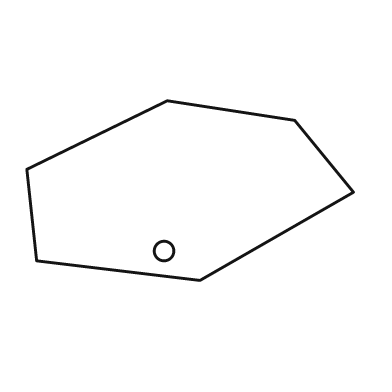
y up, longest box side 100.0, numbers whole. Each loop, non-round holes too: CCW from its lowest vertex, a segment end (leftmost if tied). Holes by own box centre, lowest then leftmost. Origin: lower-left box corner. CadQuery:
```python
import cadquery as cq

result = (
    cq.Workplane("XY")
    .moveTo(53.0, 0.0)
    .lineTo(100.0, 27.0)
    .lineTo(82.0, 49.0)
    .lineTo(43.0, 55.0)
    .lineTo(0.0, 34.0)
    .lineTo(3.0, 6.0)
    .close()
    .moveTo(42.0, 9.0)
    .circle(3.0)
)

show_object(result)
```